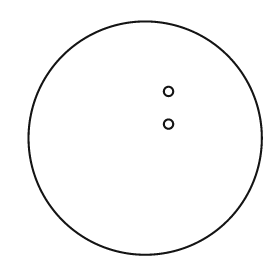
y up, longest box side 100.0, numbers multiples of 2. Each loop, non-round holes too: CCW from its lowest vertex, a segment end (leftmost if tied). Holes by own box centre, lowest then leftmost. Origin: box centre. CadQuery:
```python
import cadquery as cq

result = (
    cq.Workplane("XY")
    .moveTo(0.0, 0.0)
    .circle(50.0)
    .moveTo(10.0, 6.0)
    .circle(2.0)
    .moveTo(10.0, 20.0)
    .circle(2.0)
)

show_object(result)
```